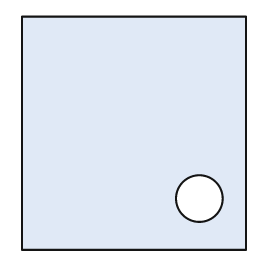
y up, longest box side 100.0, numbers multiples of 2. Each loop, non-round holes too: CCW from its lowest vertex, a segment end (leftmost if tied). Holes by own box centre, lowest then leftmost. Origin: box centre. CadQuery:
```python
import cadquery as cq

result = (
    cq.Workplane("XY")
    .moveTo(-48.0, -50.0)
    .lineTo(48.0, -50.0)
    .lineTo(48.0, 50.0)
    .lineTo(-48.0, 50.0)
    .close()
    .moveTo(28.0, -28.0)
    .circle(10.0)
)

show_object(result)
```